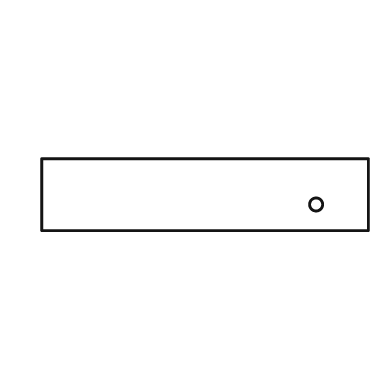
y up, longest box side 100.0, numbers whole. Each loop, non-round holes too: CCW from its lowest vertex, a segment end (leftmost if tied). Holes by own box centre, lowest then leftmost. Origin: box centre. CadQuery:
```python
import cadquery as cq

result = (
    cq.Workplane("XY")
    .moveTo(-50.0, -11.0)
    .lineTo(50.0, -11.0)
    .lineTo(50.0, 11.0)
    .lineTo(-50.0, 11.0)
    .close()
    .moveTo(34.0, -3.0)
    .circle(2.0)
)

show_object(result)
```